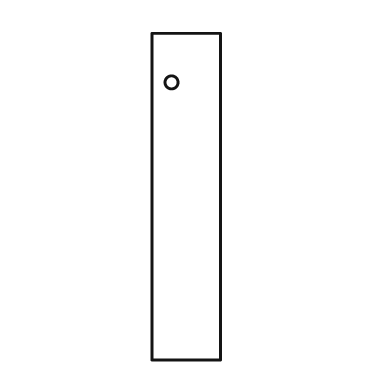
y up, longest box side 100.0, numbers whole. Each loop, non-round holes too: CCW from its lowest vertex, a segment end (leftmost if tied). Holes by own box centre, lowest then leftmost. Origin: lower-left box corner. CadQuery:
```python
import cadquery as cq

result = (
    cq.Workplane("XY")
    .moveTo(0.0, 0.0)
    .lineTo(21.0, 0.0)
    .lineTo(21.0, 100.0)
    .lineTo(0.0, 100.0)
    .close()
    .moveTo(6.0, 85.0)
    .circle(2.0)
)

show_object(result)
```